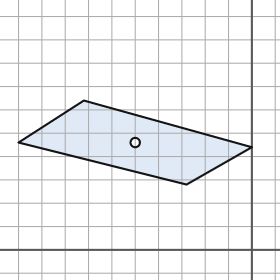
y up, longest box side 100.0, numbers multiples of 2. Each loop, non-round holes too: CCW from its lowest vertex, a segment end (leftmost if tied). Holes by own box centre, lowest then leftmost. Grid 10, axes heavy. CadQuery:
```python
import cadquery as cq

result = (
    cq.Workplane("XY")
    .moveTo(-28.0, 28.0)
    .lineTo(0.0, 44.0)
    .lineTo(-72.0, 64.0)
    .lineTo(-100.0, 46.0)
    .close()
    .moveTo(-50.0, 46.0)
    .circle(2.0)
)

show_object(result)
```